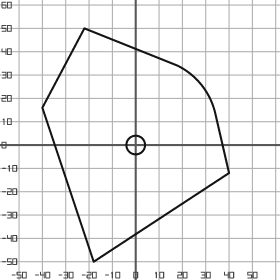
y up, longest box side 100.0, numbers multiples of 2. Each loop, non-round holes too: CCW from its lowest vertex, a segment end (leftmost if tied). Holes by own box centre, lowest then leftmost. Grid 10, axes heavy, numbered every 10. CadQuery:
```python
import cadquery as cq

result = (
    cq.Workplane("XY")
    .moveTo(-18.0, -50.0)
    .lineTo(40.0, -12.0)
    .lineTo(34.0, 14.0)
    .threePointArc((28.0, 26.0), (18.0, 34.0))
    .lineTo(-22.0, 50.0)
    .lineTo(-40.0, 16.0)
    .close()
    .moveTo(0.0, 0.0)
    .circle(4.0)
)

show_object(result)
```